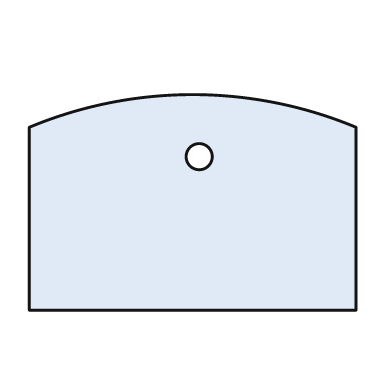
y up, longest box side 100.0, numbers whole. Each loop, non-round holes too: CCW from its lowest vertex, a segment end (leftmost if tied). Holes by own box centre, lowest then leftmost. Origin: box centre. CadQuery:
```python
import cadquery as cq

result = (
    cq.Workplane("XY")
    .moveTo(-50.0, -33.0)
    .lineTo(50.0, -33.0)
    .lineTo(50.0, 23.0)
    .threePointArc((0.0, 33.0), (-50.0, 23.0))
    .close()
    .moveTo(2.0, 14.0)
    .circle(4.0)
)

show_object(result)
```